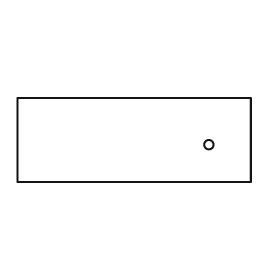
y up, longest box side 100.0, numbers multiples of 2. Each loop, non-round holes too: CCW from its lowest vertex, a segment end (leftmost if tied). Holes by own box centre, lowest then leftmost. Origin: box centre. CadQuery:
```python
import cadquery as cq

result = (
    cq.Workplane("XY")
    .moveTo(-50.0, -18.0)
    .lineTo(50.0, -18.0)
    .lineTo(50.0, 18.0)
    .lineTo(-50.0, 18.0)
    .close()
    .moveTo(32.0, -2.0)
    .circle(2.0)
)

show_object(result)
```